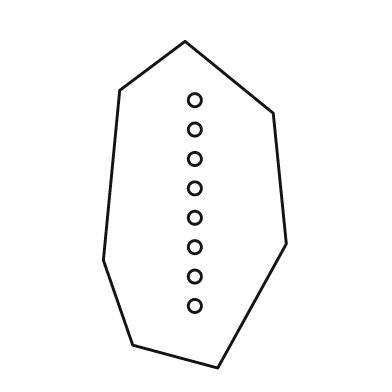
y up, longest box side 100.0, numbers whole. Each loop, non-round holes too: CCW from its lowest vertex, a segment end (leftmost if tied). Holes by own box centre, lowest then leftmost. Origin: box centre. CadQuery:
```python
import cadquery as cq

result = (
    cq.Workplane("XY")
    .moveTo(7.0, -50.0)
    .lineTo(28.0, -12.0)
    .lineTo(24.0, 28.0)
    .lineTo(-3.0, 50.0)
    .lineTo(-23.0, 35.0)
    .lineTo(-28.0, -17.0)
    .lineTo(-19.0, -43.0)
    .close()
    .moveTo(0.0, -31.0)
    .circle(2.0)
    .moveTo(0.0, -22.0)
    .circle(2.0)
    .moveTo(0.0, -13.0)
    .circle(2.0)
    .moveTo(0.0, -4.0)
    .circle(2.0)
    .moveTo(0.0, 5.0)
    .circle(2.0)
    .moveTo(0.0, 14.0)
    .circle(2.0)
    .moveTo(0.0, 23.0)
    .circle(2.0)
    .moveTo(0.0, 32.0)
    .circle(2.0)
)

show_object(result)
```